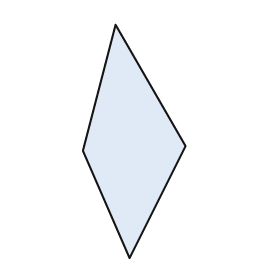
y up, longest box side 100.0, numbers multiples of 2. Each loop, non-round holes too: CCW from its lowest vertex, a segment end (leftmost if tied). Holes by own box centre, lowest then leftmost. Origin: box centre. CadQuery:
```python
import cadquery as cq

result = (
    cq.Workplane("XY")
    .moveTo(-2.0, -50.0)
    .lineTo(22.0, -2.0)
    .lineTo(-8.0, 50.0)
    .lineTo(-22.0, -4.0)
    .close()
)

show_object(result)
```